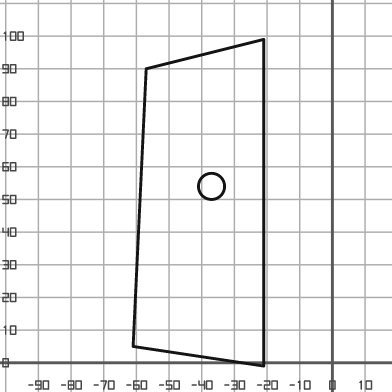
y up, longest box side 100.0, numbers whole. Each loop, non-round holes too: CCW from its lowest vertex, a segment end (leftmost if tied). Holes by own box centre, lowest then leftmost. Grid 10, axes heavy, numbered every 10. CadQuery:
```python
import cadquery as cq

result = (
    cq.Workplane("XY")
    .moveTo(-21.0, -1.0)
    .lineTo(-21.0, 99.0)
    .lineTo(-57.0, 90.0)
    .lineTo(-61.0, 5.0)
    .close()
    .moveTo(-37.0, 54.0)
    .circle(4.0)
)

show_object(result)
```